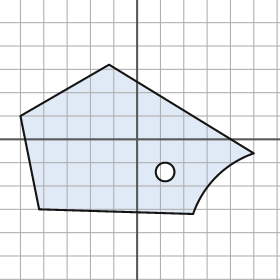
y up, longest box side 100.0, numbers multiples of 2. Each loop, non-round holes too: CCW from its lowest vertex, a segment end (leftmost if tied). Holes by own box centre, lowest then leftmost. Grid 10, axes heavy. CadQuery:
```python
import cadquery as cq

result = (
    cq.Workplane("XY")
    .moveTo(24.0, -32.0)
    .threePointArc((34.0, -16.0), (50.0, -6.0))
    .lineTo(-12.0, 32.0)
    .lineTo(-50.0, 10.0)
    .lineTo(-42.0, -30.0)
    .close()
    .moveTo(12.0, -14.0)
    .circle(4.0)
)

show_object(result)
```